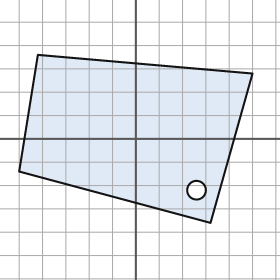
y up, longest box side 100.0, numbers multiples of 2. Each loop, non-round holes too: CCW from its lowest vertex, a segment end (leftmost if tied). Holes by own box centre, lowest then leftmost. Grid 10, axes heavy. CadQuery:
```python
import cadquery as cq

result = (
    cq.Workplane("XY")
    .moveTo(32.0, -36.0)
    .lineTo(50.0, 28.0)
    .lineTo(-42.0, 36.0)
    .lineTo(-50.0, -14.0)
    .close()
    .moveTo(26.0, -22.0)
    .circle(4.0)
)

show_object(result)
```